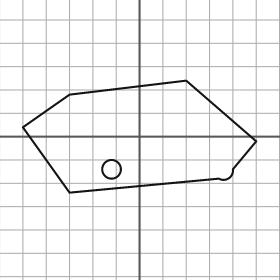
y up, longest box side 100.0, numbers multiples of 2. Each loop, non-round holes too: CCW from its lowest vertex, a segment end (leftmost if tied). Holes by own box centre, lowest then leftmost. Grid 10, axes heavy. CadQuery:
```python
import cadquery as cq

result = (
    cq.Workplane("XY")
    .moveTo(-30.0, -24.0)
    .lineTo(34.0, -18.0)
    .threePointArc((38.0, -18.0), (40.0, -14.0))
    .lineTo(50.0, -2.0)
    .lineTo(20.0, 24.0)
    .lineTo(-30.0, 18.0)
    .lineTo(-50.0, 4.0)
    .close()
    .moveTo(-12.0, -14.0)
    .circle(4.0)
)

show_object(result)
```